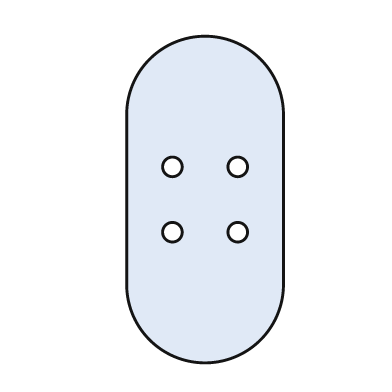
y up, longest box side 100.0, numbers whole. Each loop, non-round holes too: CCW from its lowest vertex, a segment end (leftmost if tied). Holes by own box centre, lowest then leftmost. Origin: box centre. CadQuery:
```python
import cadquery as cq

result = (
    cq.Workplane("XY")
    .moveTo(-24.0, -26.0)
    .threePointArc((0.0, -50.0), (24.0, -26.0))
    .lineTo(24.0, 26.0)
    .threePointArc((0.0, 50.0), (-24.0, 26.0))
    .close()
    .moveTo(-10.0, -10.0)
    .circle(3.0)
    .moveTo(10.0, -10.0)
    .circle(3.0)
    .moveTo(-10.0, 10.0)
    .circle(3.0)
    .moveTo(10.0, 10.0)
    .circle(3.0)
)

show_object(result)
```